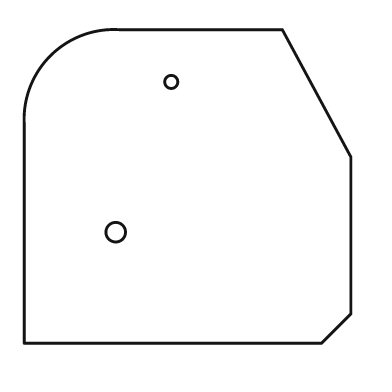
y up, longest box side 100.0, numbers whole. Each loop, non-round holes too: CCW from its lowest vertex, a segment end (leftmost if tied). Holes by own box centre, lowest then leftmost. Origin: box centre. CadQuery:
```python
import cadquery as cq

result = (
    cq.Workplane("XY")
    .moveTo(-50.0, -48.0)
    .lineTo(41.0, -48.0)
    .lineTo(50.0, -39.0)
    .lineTo(50.0, 9.0)
    .lineTo(29.0, 48.0)
    .lineTo(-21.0, 48.0)
    .threePointArc((-42.0, 40.0), (-50.0, 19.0))
    .close()
    .moveTo(-22.0, -14.0)
    .circle(3.0)
    .moveTo(-5.0, 32.0)
    .circle(2.0)
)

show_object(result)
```